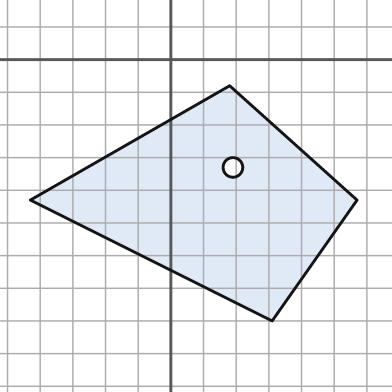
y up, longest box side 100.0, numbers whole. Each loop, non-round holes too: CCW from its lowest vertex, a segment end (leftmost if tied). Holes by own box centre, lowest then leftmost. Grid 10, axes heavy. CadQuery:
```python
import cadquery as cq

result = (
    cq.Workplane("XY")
    .moveTo(31.0, -80.0)
    .lineTo(57.0, -43.0)
    .lineTo(18.0, -8.0)
    .lineTo(-43.0, -43.0)
    .close()
    .moveTo(19.0, -33.0)
    .circle(3.0)
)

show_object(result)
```